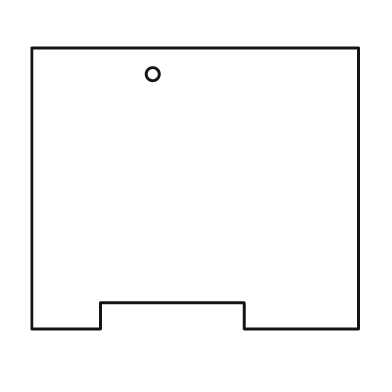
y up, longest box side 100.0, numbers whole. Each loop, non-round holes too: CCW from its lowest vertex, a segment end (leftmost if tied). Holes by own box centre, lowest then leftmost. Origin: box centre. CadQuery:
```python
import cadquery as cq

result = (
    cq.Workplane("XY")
    .moveTo(-50.0, -43.0)
    .lineTo(-29.0, -43.0)
    .lineTo(-29.0, -35.0)
    .lineTo(15.0, -35.0)
    .lineTo(15.0, -43.0)
    .lineTo(50.0, -43.0)
    .lineTo(50.0, 43.0)
    .lineTo(-50.0, 43.0)
    .close()
    .moveTo(-13.0, 35.0)
    .circle(2.0)
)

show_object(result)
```